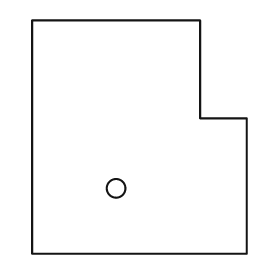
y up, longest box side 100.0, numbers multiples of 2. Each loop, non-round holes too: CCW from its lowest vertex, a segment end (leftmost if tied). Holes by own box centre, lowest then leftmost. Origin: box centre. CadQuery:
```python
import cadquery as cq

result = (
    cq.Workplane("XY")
    .moveTo(-46.0, -50.0)
    .lineTo(46.0, -50.0)
    .lineTo(46.0, 8.0)
    .lineTo(26.0, 8.0)
    .lineTo(26.0, 50.0)
    .lineTo(-46.0, 50.0)
    .close()
    .moveTo(-10.0, -22.0)
    .circle(4.0)
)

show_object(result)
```